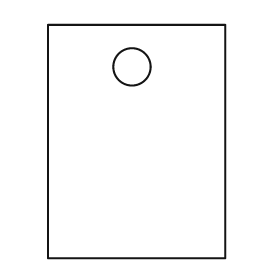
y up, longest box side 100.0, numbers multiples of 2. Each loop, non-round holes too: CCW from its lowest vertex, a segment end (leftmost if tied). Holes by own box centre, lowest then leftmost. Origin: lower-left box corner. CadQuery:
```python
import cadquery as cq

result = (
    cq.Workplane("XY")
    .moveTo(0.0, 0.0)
    .lineTo(76.0, 0.0)
    .lineTo(76.0, 100.0)
    .lineTo(0.0, 100.0)
    .close()
    .moveTo(36.0, 82.0)
    .circle(8.0)
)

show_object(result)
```